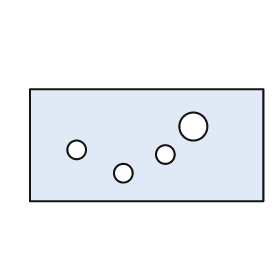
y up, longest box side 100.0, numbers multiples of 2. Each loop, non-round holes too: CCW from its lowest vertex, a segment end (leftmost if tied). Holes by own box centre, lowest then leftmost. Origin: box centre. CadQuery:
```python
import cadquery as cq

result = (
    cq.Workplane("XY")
    .moveTo(-50.0, -24.0)
    .lineTo(50.0, -24.0)
    .lineTo(50.0, 24.0)
    .lineTo(-50.0, 24.0)
    .close()
    .moveTo(-10.0, -12.0)
    .circle(4.0)
    .moveTo(8.0, -4.0)
    .circle(4.0)
    .moveTo(-30.0, -2.0)
    .circle(4.0)
    .moveTo(20.0, 8.0)
    .circle(6.0)
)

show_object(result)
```